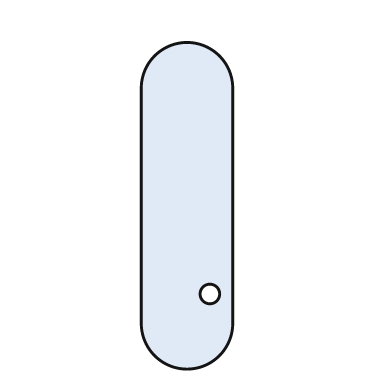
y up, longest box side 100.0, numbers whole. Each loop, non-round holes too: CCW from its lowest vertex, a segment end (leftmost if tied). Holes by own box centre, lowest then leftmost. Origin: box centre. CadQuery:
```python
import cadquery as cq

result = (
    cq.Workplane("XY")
    .moveTo(-14.0, -36.0)
    .threePointArc((0.0, -50.0), (14.0, -36.0))
    .lineTo(14.0, 36.0)
    .threePointArc((0.0, 50.0), (-14.0, 36.0))
    .close()
    .moveTo(7.0, -27.0)
    .circle(3.0)
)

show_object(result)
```